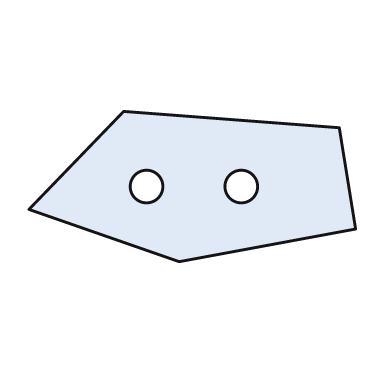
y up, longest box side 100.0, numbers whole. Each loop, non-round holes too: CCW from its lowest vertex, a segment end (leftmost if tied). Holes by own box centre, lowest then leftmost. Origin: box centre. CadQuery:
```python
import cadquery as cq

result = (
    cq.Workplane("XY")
    .moveTo(-4.0, -23.0)
    .lineTo(50.0, -13.0)
    .lineTo(45.0, 18.0)
    .lineTo(-21.0, 23.0)
    .lineTo(-50.0, -7.0)
    .close()
    .moveTo(-14.0, 0.0)
    .circle(5.0)
    .moveTo(15.0, 0.0)
    .circle(5.0)
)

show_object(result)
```